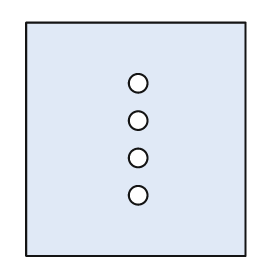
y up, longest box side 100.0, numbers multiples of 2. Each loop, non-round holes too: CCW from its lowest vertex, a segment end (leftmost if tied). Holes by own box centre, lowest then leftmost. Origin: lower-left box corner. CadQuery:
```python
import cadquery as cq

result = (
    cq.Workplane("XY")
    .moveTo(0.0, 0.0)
    .lineTo(94.0, 0.0)
    .lineTo(94.0, 100.0)
    .lineTo(0.0, 100.0)
    .close()
    .moveTo(48.0, 26.0)
    .circle(4.0)
    .moveTo(48.0, 42.0)
    .circle(4.0)
    .moveTo(48.0, 58.0)
    .circle(4.0)
    .moveTo(48.0, 74.0)
    .circle(4.0)
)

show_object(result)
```